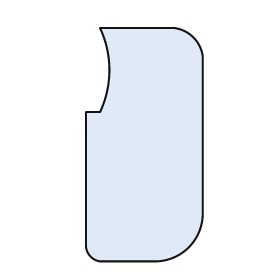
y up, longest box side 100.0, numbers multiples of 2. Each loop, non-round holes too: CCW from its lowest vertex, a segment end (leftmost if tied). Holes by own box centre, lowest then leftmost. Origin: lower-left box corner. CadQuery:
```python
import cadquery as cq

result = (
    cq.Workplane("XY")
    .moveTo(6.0, 0.0)
    .lineTo(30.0, 0.0)
    .threePointArc((44.0, 6.0), (50.0, 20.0))
    .lineTo(50.0, 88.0)
    .threePointArc((46.0, 96.0), (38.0, 100.0))
    .lineTo(6.0, 100.0)
    .threePointArc((10.0, 82.0), (6.0, 64.0))
    .lineTo(0.0, 64.0)
    .lineTo(0.0, 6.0)
    .threePointArc((2.0, 2.0), (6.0, 0.0))
    .close()
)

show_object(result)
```